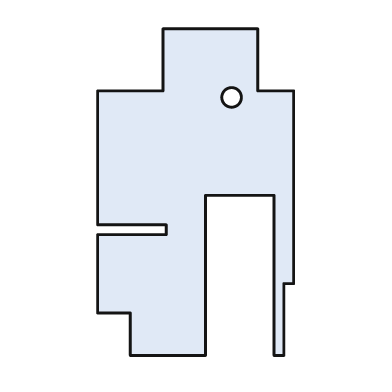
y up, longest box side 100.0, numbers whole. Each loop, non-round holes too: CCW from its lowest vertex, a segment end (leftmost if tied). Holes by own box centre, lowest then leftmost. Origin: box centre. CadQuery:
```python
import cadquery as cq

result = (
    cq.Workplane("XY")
    .moveTo(-20.0, -50.0)
    .lineTo(3.0, -50.0)
    .lineTo(3.0, -1.0)
    .lineTo(24.0, -1.0)
    .lineTo(24.0, -50.0)
    .lineTo(27.0, -50.0)
    .lineTo(27.0, -28.0)
    .lineTo(30.0, -28.0)
    .lineTo(30.0, 31.0)
    .lineTo(19.0, 31.0)
    .lineTo(19.0, 50.0)
    .lineTo(-10.0, 50.0)
    .lineTo(-10.0, 31.0)
    .lineTo(-30.0, 31.0)
    .lineTo(-30.0, -10.0)
    .lineTo(-9.0, -10.0)
    .lineTo(-9.0, -13.0)
    .lineTo(-30.0, -13.0)
    .lineTo(-30.0, -37.0)
    .lineTo(-20.0, -37.0)
    .close()
    .moveTo(11.0, 29.0)
    .circle(3.0)
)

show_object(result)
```